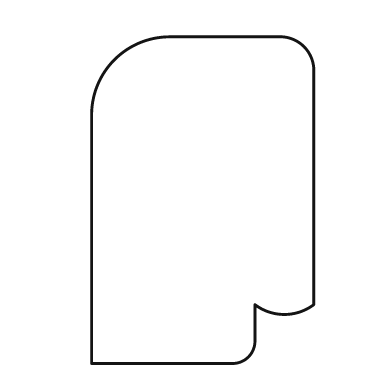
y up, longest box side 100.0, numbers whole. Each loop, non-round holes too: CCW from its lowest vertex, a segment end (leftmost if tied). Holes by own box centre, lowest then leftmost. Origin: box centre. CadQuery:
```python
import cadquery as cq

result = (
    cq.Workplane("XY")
    .moveTo(-34.0, -50.0)
    .lineTo(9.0, -50.0)
    .threePointArc((14.0, -48.0), (16.0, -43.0))
    .lineTo(16.0, -32.0)
    .threePointArc((25.0, -35.0), (34.0, -32.0))
    .lineTo(34.0, 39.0)
    .threePointArc((31.0, 47.0), (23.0, 50.0))
    .lineTo(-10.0, 50.0)
    .threePointArc((-27.0, 43.0), (-34.0, 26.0))
    .close()
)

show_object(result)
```